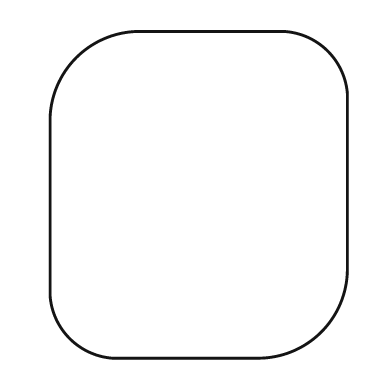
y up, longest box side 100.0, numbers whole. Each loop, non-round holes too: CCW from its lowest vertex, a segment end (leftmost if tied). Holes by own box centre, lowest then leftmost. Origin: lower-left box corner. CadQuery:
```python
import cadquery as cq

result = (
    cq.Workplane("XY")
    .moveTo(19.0, 0.0)
    .lineTo(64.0, 0.0)
    .threePointArc((83.0, 8.0), (91.0, 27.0))
    .lineTo(91.0, 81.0)
    .threePointArc((85.0, 94.0), (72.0, 100.0))
    .lineTo(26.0, 100.0)
    .threePointArc((8.0, 92.0), (0.0, 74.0))
    .lineTo(0.0, 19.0)
    .threePointArc((6.0, 6.0), (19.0, 0.0))
    .close()
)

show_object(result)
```